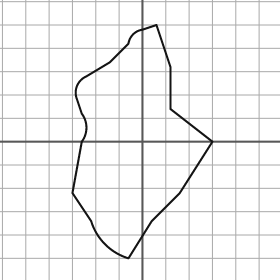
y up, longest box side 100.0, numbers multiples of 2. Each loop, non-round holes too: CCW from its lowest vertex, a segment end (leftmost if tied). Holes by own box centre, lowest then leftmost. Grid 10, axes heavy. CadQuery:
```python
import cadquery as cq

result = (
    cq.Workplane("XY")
    .moveTo(-6.0, -50.0)
    .lineTo(4.0, -34.0)
    .lineTo(16.0, -22.0)
    .lineTo(30.0, 0.0)
    .lineTo(12.0, 14.0)
    .lineTo(12.0, 32.0)
    .lineTo(6.0, 50.0)
    .lineTo(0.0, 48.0)
    .threePointArc((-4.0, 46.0), (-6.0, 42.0))
    .lineTo(-14.0, 34.0)
    .lineTo(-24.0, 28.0)
    .threePointArc((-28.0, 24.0), (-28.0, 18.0))
    .lineTo(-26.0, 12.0)
    .threePointArc((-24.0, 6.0), (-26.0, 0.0))
    .lineTo(-30.0, -22.0)
    .lineTo(-22.0, -34.0)
    .threePointArc((-16.0, -44.0), (-6.0, -50.0))
    .close()
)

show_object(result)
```